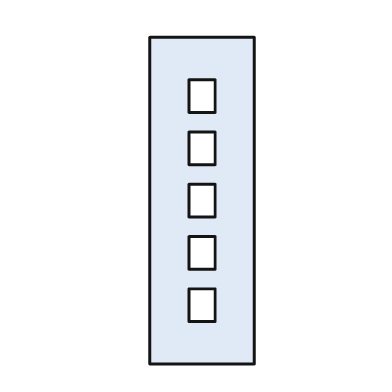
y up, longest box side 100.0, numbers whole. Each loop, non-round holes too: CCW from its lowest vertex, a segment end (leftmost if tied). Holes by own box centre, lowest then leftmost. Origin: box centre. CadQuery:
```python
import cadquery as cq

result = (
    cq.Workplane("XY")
    .moveTo(-16.0, -50.0)
    .lineTo(16.0, -50.0)
    .lineTo(16.0, 50.0)
    .lineTo(-16.0, 50.0)
    .close()
    .moveTo(-4.0, -37.0)
    .lineTo(4.0, -37.0)
    .lineTo(4.0, -27.0)
    .lineTo(-4.0, -27.0)
    .close()
    .moveTo(-4.0, -21.0)
    .lineTo(4.0, -21.0)
    .lineTo(4.0, -11.0)
    .lineTo(-4.0, -11.0)
    .close()
    .moveTo(-4.0, -5.0)
    .lineTo(4.0, -5.0)
    .lineTo(4.0, 5.0)
    .lineTo(-4.0, 5.0)
    .close()
    .moveTo(-4.0, 11.0)
    .lineTo(4.0, 11.0)
    .lineTo(4.0, 21.0)
    .lineTo(-4.0, 21.0)
    .close()
    .moveTo(-4.0, 27.0)
    .lineTo(4.0, 27.0)
    .lineTo(4.0, 37.0)
    .lineTo(-4.0, 37.0)
    .close()
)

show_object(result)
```